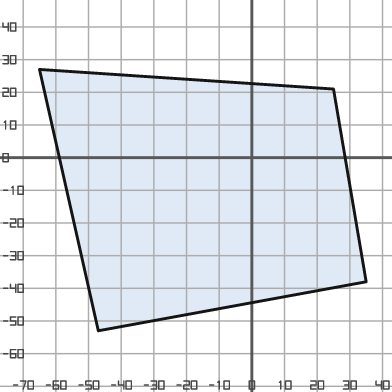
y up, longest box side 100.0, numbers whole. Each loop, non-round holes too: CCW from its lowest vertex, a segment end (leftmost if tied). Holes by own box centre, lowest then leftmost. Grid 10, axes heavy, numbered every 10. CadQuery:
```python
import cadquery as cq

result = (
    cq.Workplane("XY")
    .moveTo(-47.0, -53.0)
    .lineTo(35.0, -38.0)
    .lineTo(25.0, 21.0)
    .lineTo(-65.0, 27.0)
    .close()
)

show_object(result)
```